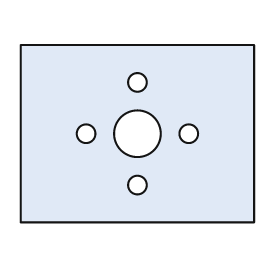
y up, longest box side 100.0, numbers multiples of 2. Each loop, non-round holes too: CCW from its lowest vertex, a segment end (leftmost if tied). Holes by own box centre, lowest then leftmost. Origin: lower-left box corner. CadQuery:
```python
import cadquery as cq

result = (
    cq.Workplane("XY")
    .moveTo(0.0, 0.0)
    .lineTo(100.0, 0.0)
    .lineTo(100.0, 76.0)
    .lineTo(0.0, 76.0)
    .close()
    .moveTo(50.0, 16.0)
    .circle(4.0)
    .moveTo(28.0, 38.0)
    .circle(4.0)
    .moveTo(50.0, 38.0)
    .circle(10.0)
    .moveTo(72.0, 38.0)
    .circle(4.0)
    .moveTo(50.0, 60.0)
    .circle(4.0)
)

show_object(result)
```